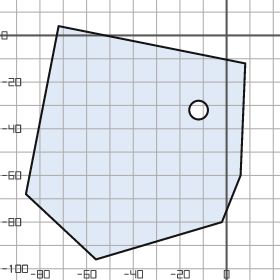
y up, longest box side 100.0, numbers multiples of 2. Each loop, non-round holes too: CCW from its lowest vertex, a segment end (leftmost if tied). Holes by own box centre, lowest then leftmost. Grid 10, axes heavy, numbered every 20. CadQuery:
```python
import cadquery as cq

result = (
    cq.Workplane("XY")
    .moveTo(-56.0, -96.0)
    .lineTo(-2.0, -80.0)
    .lineTo(6.0, -60.0)
    .lineTo(8.0, -12.0)
    .lineTo(-72.0, 4.0)
    .lineTo(-86.0, -68.0)
    .close()
    .moveTo(-12.0, -32.0)
    .circle(4.0)
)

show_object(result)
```